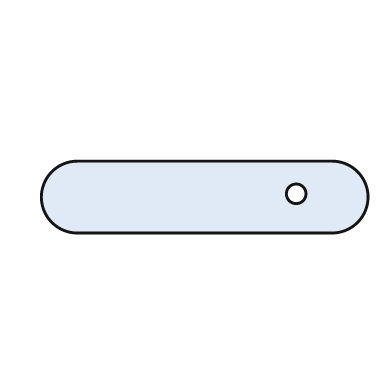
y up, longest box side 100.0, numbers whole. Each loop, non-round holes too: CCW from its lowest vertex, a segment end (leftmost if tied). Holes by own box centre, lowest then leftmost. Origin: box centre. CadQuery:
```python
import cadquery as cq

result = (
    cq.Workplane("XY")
    .moveTo(-39.0, -11.0)
    .lineTo(39.0, -11.0)
    .threePointArc((50.0, 0.0), (39.0, 11.0))
    .lineTo(-39.0, 11.0)
    .threePointArc((-50.0, 0.0), (-39.0, -11.0))
    .close()
    .moveTo(28.0, 1.0)
    .circle(3.0)
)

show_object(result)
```